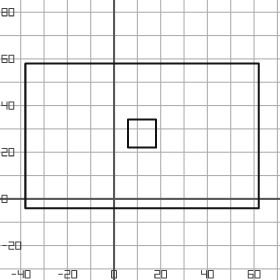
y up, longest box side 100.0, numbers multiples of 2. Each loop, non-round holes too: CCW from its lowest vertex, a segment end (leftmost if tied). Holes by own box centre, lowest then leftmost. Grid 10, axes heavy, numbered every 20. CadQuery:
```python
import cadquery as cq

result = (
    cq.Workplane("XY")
    .moveTo(-38.0, -4.0)
    .lineTo(62.0, -4.0)
    .lineTo(62.0, 58.0)
    .lineTo(-38.0, 58.0)
    .close()
    .moveTo(6.0, 22.0)
    .lineTo(18.0, 22.0)
    .lineTo(18.0, 34.0)
    .lineTo(6.0, 34.0)
    .close()
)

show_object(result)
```